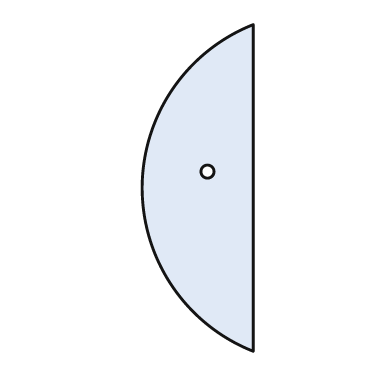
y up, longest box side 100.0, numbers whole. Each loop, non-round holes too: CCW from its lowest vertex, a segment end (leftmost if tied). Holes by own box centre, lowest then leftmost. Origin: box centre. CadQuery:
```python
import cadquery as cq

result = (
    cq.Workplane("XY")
    .moveTo(17.0, -50.0)
    .lineTo(17.0, 50.0)
    .threePointArc((-17.0, 0.0), (17.0, -50.0))
    .close()
    .moveTo(3.0, 5.0)
    .circle(2.0)
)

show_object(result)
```